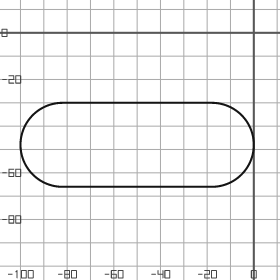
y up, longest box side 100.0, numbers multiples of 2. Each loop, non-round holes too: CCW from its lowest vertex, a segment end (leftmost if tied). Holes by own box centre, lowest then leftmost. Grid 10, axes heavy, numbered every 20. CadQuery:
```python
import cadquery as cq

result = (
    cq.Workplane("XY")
    .moveTo(-82.0, -66.0)
    .lineTo(-18.0, -66.0)
    .threePointArc((0.0, -48.0), (-18.0, -30.0))
    .lineTo(-82.0, -30.0)
    .threePointArc((-100.0, -48.0), (-82.0, -66.0))
    .close()
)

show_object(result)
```